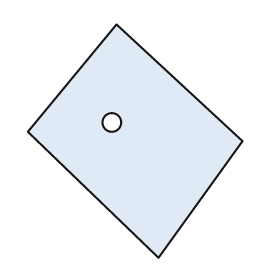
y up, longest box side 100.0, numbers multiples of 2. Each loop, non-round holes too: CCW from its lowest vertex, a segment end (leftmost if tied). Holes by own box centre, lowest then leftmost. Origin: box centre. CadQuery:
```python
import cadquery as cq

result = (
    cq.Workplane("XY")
    .moveTo(10.0, -50.0)
    .lineTo(46.0, 0.0)
    .lineTo(-8.0, 50.0)
    .lineTo(-46.0, 4.0)
    .close()
    .moveTo(-10.0, 8.0)
    .circle(4.0)
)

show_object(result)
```